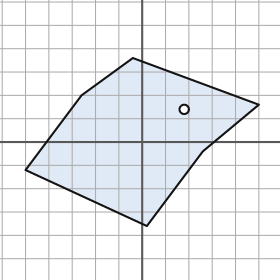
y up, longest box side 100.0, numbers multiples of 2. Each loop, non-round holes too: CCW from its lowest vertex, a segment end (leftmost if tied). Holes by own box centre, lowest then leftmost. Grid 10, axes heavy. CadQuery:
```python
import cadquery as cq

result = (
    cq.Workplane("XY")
    .moveTo(2.0, -36.0)
    .lineTo(26.0, -4.0)
    .lineTo(50.0, 16.0)
    .lineTo(-4.0, 36.0)
    .lineTo(-26.0, 20.0)
    .lineTo(-50.0, -12.0)
    .close()
    .moveTo(18.0, 14.0)
    .circle(2.0)
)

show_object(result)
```